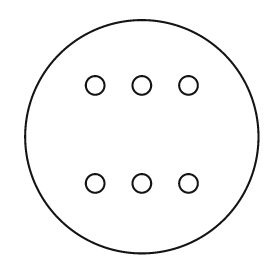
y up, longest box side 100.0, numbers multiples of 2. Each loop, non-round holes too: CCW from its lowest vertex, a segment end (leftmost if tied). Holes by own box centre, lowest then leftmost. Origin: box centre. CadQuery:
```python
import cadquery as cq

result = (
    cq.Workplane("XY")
    .moveTo(0.0, 0.0)
    .circle(50.0)
    .moveTo(-20.0, -20.0)
    .circle(4.0)
    .moveTo(0.0, -20.0)
    .circle(4.0)
    .moveTo(20.0, -20.0)
    .circle(4.0)
    .moveTo(-20.0, 22.0)
    .circle(4.0)
    .moveTo(0.0, 22.0)
    .circle(4.0)
    .moveTo(20.0, 22.0)
    .circle(4.0)
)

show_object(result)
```